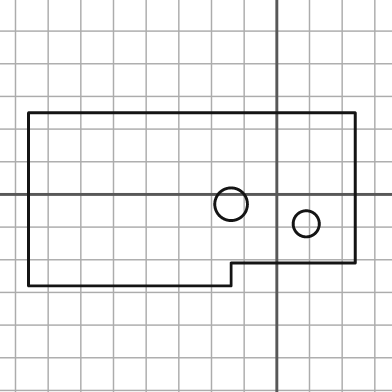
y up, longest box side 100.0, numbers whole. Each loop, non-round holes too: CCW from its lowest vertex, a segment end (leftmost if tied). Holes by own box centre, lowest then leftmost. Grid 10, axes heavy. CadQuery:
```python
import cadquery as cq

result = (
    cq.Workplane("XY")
    .moveTo(-76.0, -28.0)
    .lineTo(-14.0, -28.0)
    .lineTo(-14.0, -21.0)
    .lineTo(24.0, -21.0)
    .lineTo(24.0, 25.0)
    .lineTo(-76.0, 25.0)
    .close()
    .moveTo(9.0, -9.0)
    .circle(4.0)
    .moveTo(-14.0, -3.0)
    .circle(5.0)
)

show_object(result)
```